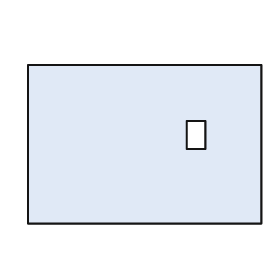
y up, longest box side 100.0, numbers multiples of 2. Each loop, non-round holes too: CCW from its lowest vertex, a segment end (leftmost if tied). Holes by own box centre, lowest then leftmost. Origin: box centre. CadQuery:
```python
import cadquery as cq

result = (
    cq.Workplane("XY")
    .moveTo(-50.0, -34.0)
    .lineTo(50.0, -34.0)
    .lineTo(50.0, 34.0)
    .lineTo(-50.0, 34.0)
    .close()
    .moveTo(18.0, -2.0)
    .lineTo(26.0, -2.0)
    .lineTo(26.0, 10.0)
    .lineTo(18.0, 10.0)
    .close()
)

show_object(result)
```